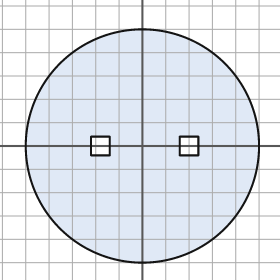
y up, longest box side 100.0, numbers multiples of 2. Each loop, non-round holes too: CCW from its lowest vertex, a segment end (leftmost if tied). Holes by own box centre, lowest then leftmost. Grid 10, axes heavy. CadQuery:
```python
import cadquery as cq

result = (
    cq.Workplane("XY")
    .moveTo(0.0, 0.0)
    .circle(50.0)
    .moveTo(-22.0, -4.0)
    .lineTo(-14.0, -4.0)
    .lineTo(-14.0, 4.0)
    .lineTo(-22.0, 4.0)
    .close()
    .moveTo(16.0, -4.0)
    .lineTo(24.0, -4.0)
    .lineTo(24.0, 4.0)
    .lineTo(16.0, 4.0)
    .close()
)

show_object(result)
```